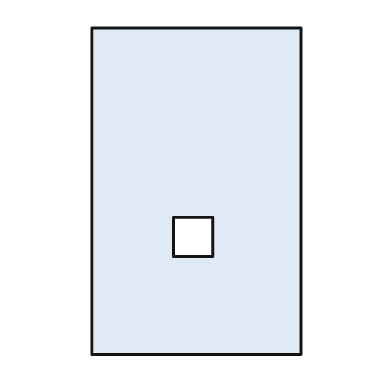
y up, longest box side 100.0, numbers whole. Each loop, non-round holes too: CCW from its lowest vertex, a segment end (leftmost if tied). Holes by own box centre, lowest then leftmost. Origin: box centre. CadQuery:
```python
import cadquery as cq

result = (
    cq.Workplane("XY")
    .moveTo(-32.0, -50.0)
    .lineTo(32.0, -50.0)
    .lineTo(32.0, 50.0)
    .lineTo(-32.0, 50.0)
    .close()
    .moveTo(-7.0, -20.0)
    .lineTo(5.0, -20.0)
    .lineTo(5.0, -8.0)
    .lineTo(-7.0, -8.0)
    .close()
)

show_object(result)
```